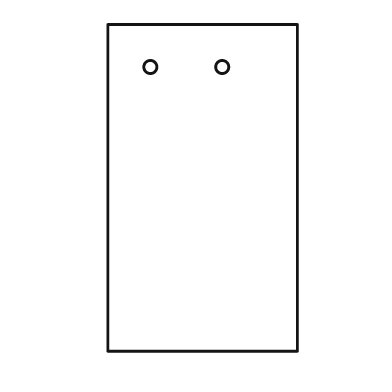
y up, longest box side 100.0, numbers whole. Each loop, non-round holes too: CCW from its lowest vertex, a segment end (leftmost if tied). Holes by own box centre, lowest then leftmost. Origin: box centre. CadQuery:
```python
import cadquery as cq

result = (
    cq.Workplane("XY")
    .moveTo(-29.0, -50.0)
    .lineTo(29.0, -50.0)
    .lineTo(29.0, 50.0)
    .lineTo(-29.0, 50.0)
    .close()
    .moveTo(-16.0, 37.0)
    .circle(2.0)
    .moveTo(6.0, 37.0)
    .circle(2.0)
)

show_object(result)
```